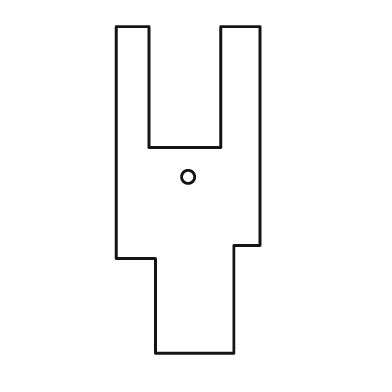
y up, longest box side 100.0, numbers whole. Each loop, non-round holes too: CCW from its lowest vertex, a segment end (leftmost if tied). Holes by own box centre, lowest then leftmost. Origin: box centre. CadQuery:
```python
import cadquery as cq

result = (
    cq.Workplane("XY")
    .moveTo(-10.0, -50.0)
    .lineTo(14.0, -50.0)
    .lineTo(14.0, -17.0)
    .lineTo(22.0, -17.0)
    .lineTo(22.0, 50.0)
    .lineTo(10.0, 50.0)
    .lineTo(10.0, 13.0)
    .lineTo(-12.0, 13.0)
    .lineTo(-12.0, 50.0)
    .lineTo(-22.0, 50.0)
    .lineTo(-22.0, -21.0)
    .lineTo(-10.0, -21.0)
    .close()
    .moveTo(0.0, 4.0)
    .circle(2.0)
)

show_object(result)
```